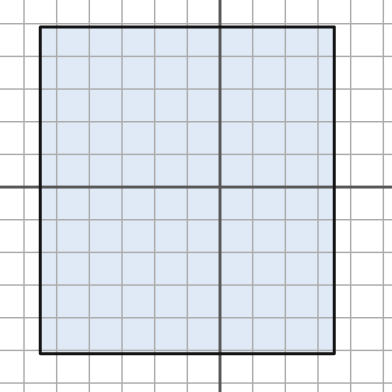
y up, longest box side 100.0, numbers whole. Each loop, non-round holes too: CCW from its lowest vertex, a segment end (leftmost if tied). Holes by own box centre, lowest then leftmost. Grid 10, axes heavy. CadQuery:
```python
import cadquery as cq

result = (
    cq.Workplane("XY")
    .moveTo(-55.0, -51.0)
    .lineTo(35.0, -51.0)
    .lineTo(35.0, 49.0)
    .lineTo(-55.0, 49.0)
    .close()
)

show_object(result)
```